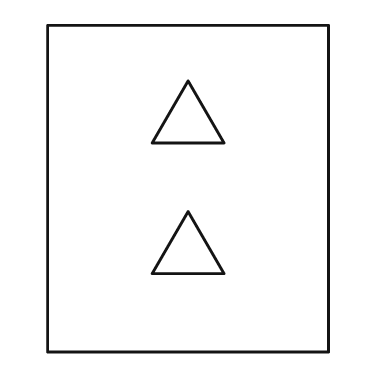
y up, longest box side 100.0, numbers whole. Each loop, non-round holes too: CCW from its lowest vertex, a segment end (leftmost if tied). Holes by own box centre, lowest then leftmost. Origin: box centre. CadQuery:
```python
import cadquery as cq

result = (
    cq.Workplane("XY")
    .moveTo(-43.0, -50.0)
    .lineTo(43.0, -50.0)
    .lineTo(43.0, 50.0)
    .lineTo(-43.0, 50.0)
    .close()
    .moveTo(-11.0, -26.0)
    .lineTo(11.0, -26.0)
    .lineTo(0.0, -7.0)
    .close()
    .moveTo(-11.0, 14.0)
    .lineTo(11.0, 14.0)
    .lineTo(0.0, 33.0)
    .close()
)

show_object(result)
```